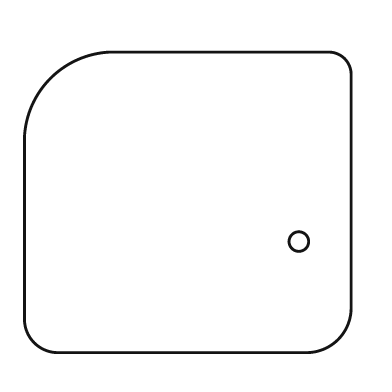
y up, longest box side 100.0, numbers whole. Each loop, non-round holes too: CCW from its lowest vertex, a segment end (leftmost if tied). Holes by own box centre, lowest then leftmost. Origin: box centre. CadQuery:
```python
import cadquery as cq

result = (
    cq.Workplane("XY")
    .moveTo(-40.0, -46.0)
    .lineTo(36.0, -46.0)
    .threePointArc((46.0, -42.0), (50.0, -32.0))
    .lineTo(50.0, 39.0)
    .threePointArc((48.0, 44.0), (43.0, 46.0))
    .lineTo(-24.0, 46.0)
    .threePointArc((-42.0, 38.0), (-50.0, 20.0))
    .lineTo(-50.0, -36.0)
    .threePointArc((-47.0, -43.0), (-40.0, -46.0))
    .close()
    .moveTo(34.0, -12.0)
    .circle(3.0)
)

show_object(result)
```